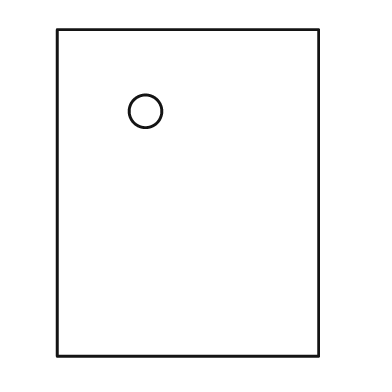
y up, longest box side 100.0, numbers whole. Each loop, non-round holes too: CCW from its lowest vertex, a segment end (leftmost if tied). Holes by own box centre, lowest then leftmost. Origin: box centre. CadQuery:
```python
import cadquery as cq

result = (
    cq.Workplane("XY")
    .moveTo(-40.0, -50.0)
    .lineTo(40.0, -50.0)
    .lineTo(40.0, 50.0)
    .lineTo(-40.0, 50.0)
    .close()
    .moveTo(-13.0, 25.0)
    .circle(5.0)
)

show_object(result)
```